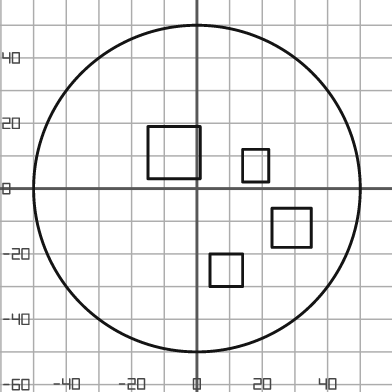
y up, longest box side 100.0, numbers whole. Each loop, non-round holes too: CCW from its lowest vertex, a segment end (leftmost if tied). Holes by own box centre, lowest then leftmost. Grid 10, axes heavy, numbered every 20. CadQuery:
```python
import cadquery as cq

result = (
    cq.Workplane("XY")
    .moveTo(0.0, 0.0)
    .circle(50.0)
    .moveTo(4.0, -30.0)
    .lineTo(14.0, -30.0)
    .lineTo(14.0, -20.0)
    .lineTo(4.0, -20.0)
    .close()
    .moveTo(23.0, -18.0)
    .lineTo(35.0, -18.0)
    .lineTo(35.0, -6.0)
    .lineTo(23.0, -6.0)
    .close()
    .moveTo(14.0, 2.0)
    .lineTo(22.0, 2.0)
    .lineTo(22.0, 12.0)
    .lineTo(14.0, 12.0)
    .close()
    .moveTo(-15.0, 3.0)
    .lineTo(1.0, 3.0)
    .lineTo(1.0, 19.0)
    .lineTo(-15.0, 19.0)
    .close()
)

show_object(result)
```